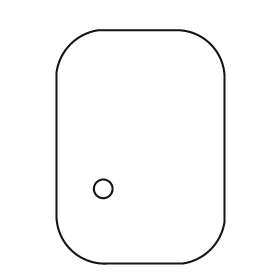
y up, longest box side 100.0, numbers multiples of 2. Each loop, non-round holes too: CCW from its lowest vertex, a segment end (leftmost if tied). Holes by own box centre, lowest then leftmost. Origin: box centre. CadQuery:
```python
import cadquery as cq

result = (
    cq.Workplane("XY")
    .moveTo(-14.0, -50.0)
    .lineTo(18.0, -50.0)
    .threePointArc((30.0, -44.0), (36.0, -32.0))
    .lineTo(36.0, 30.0)
    .threePointArc((30.0, 44.0), (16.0, 50.0))
    .lineTo(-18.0, 50.0)
    .threePointArc((-30.0, 44.0), (-36.0, 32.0))
    .lineTo(-36.0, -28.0)
    .threePointArc((-30.0, -44.0), (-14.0, -50.0))
    .close()
    .moveTo(-16.0, -18.0)
    .circle(4.0)
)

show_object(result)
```